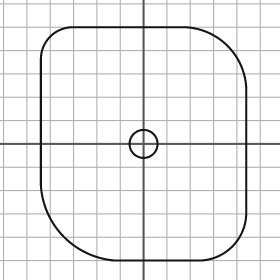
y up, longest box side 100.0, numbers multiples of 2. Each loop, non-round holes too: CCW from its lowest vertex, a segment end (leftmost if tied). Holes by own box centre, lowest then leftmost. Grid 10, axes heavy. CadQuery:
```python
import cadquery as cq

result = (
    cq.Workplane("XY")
    .moveTo(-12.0, -50.0)
    .lineTo(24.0, -50.0)
    .threePointArc((38.0, -44.0), (44.0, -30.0))
    .lineTo(44.0, 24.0)
    .threePointArc((36.0, 42.0), (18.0, 50.0))
    .lineTo(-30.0, 50.0)
    .threePointArc((-40.0, 46.0), (-44.0, 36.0))
    .lineTo(-44.0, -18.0)
    .threePointArc((-34.0, -40.0), (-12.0, -50.0))
    .close()
    .moveTo(0.0, 0.0)
    .circle(6.0)
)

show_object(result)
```